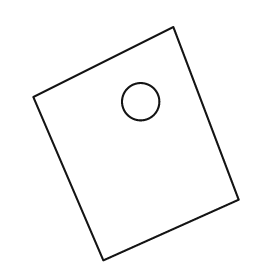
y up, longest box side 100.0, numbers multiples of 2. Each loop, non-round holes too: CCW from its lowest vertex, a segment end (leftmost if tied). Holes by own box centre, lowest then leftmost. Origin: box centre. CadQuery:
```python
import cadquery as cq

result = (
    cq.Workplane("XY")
    .moveTo(-14.0, -50.0)
    .lineTo(44.0, -24.0)
    .lineTo(16.0, 50.0)
    .lineTo(-44.0, 20.0)
    .close()
    .moveTo(2.0, 18.0)
    .circle(8.0)
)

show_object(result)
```